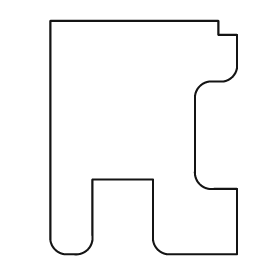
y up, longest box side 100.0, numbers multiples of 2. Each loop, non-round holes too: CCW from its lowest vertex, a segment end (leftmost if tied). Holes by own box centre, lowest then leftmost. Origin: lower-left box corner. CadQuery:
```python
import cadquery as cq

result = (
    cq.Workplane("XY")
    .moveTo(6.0, 0.0)
    .lineTo(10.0, 0.0)
    .threePointArc((16.0, 2.0), (18.0, 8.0))
    .lineTo(18.0, 32.0)
    .lineTo(44.0, 32.0)
    .lineTo(44.0, 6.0)
    .threePointArc((46.0, 2.0), (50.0, 0.0))
    .lineTo(80.0, 0.0)
    .lineTo(80.0, 28.0)
    .lineTo(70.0, 28.0)
    .threePointArc((64.0, 30.0), (62.0, 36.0))
    .lineTo(62.0, 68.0)
    .threePointArc((64.0, 72.0), (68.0, 74.0))
    .lineTo(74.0, 74.0)
    .threePointArc((78.0, 76.0), (80.0, 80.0))
    .lineTo(80.0, 94.0)
    .lineTo(72.0, 94.0)
    .lineTo(72.0, 100.0)
    .lineTo(0.0, 100.0)
    .lineTo(0.0, 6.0)
    .threePointArc((2.0, 2.0), (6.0, 0.0))
    .close()
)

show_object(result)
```